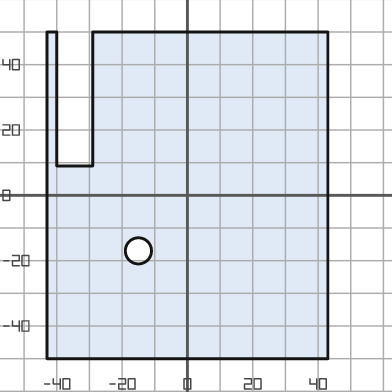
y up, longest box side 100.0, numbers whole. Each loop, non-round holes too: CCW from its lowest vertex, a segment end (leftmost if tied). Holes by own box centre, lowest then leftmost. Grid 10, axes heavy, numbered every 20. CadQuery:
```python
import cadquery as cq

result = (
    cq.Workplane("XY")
    .moveTo(-43.0, -50.0)
    .lineTo(43.0, -50.0)
    .lineTo(43.0, 50.0)
    .lineTo(-29.0, 50.0)
    .lineTo(-29.0, 9.0)
    .lineTo(-40.0, 9.0)
    .lineTo(-40.0, 50.0)
    .lineTo(-43.0, 50.0)
    .close()
    .moveTo(-15.0, -17.0)
    .circle(4.0)
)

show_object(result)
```